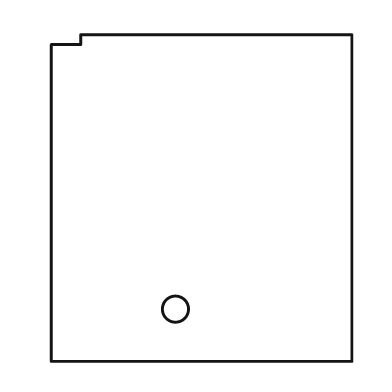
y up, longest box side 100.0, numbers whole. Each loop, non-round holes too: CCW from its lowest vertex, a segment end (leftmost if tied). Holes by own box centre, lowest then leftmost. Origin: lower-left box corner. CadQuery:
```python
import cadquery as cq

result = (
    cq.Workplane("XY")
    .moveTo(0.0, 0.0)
    .lineTo(92.0, 0.0)
    .lineTo(92.0, 100.0)
    .lineTo(9.0, 100.0)
    .lineTo(9.0, 97.0)
    .lineTo(0.0, 97.0)
    .close()
    .moveTo(38.0, 16.0)
    .circle(4.0)
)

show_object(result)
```